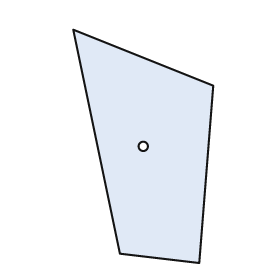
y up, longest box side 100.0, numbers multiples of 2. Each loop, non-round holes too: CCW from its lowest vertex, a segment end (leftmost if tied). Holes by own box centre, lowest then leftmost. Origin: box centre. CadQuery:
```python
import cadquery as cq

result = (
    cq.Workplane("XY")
    .moveTo(24.0, -50.0)
    .lineTo(30.0, 26.0)
    .lineTo(-30.0, 50.0)
    .lineTo(-10.0, -46.0)
    .close()
    .moveTo(0.0, 0.0)
    .circle(2.0)
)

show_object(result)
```